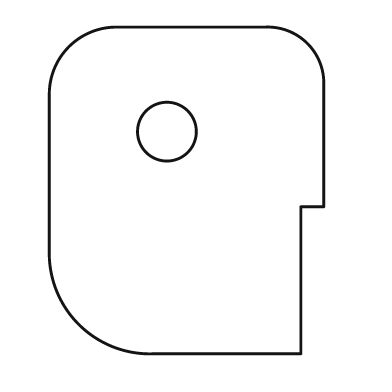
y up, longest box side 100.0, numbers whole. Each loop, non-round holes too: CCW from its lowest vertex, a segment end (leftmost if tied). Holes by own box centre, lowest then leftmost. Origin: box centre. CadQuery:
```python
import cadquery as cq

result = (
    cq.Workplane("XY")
    .moveTo(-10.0, -50.0)
    .lineTo(35.0, -50.0)
    .lineTo(35.0, -5.0)
    .lineTo(42.0, -5.0)
    .lineTo(42.0, 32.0)
    .threePointArc((37.0, 45.0), (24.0, 50.0))
    .lineTo(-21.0, 50.0)
    .threePointArc((-36.0, 44.0), (-42.0, 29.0))
    .lineTo(-42.0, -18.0)
    .threePointArc((-33.0, -41.0), (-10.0, -50.0))
    .close()
    .moveTo(-6.0, 18.0)
    .circle(9.0)
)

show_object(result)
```